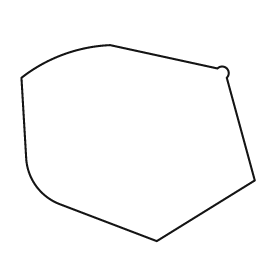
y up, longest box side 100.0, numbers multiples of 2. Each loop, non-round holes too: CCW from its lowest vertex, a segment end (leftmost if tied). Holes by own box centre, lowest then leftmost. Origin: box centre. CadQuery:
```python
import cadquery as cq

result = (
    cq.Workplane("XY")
    .moveTo(8.0, -42.0)
    .lineTo(50.0, -16.0)
    .lineTo(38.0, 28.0)
    .threePointArc((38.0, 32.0), (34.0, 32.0))
    .lineTo(-12.0, 42.0)
    .threePointArc((-32.0, 38.0), (-50.0, 28.0))
    .lineTo(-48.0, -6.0)
    .threePointArc((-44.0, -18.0), (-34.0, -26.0))
    .close()
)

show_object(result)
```